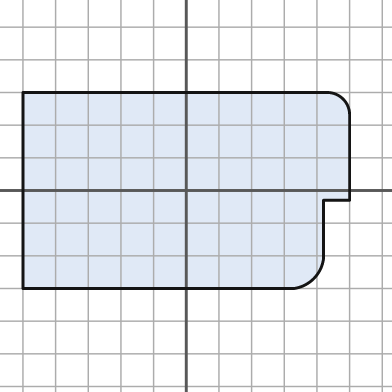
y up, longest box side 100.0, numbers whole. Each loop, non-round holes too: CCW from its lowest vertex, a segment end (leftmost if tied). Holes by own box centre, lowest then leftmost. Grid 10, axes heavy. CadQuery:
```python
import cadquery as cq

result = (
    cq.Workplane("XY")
    .moveTo(-50.0, -30.0)
    .lineTo(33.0, -30.0)
    .threePointArc((39.0, -27.0), (42.0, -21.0))
    .lineTo(42.0, -3.0)
    .lineTo(50.0, -3.0)
    .lineTo(50.0, 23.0)
    .threePointArc((48.0, 28.0), (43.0, 30.0))
    .lineTo(-50.0, 30.0)
    .close()
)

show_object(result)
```